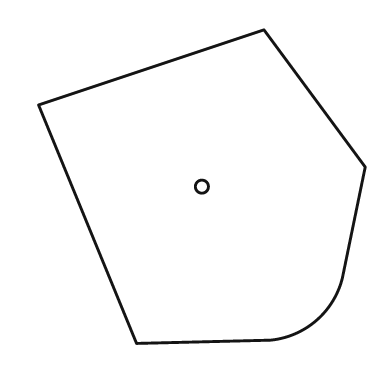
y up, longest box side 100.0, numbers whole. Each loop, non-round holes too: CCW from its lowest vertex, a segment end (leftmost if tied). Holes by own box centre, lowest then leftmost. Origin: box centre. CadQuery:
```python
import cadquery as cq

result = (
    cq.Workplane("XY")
    .moveTo(-20.0, -48.0)
    .lineTo(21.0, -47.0)
    .threePointArc((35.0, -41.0), (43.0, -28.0))
    .lineTo(50.0, 6.0)
    .lineTo(19.0, 48.0)
    .lineTo(-50.0, 25.0)
    .close()
    .moveTo(0.0, 0.0)
    .circle(2.0)
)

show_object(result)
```